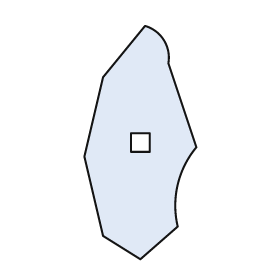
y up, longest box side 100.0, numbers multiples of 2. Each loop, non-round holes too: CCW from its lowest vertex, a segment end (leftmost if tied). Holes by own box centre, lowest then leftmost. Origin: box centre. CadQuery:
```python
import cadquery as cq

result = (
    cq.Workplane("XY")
    .moveTo(0.0, -50.0)
    .lineTo(16.0, -36.0)
    .threePointArc((16.0, -18.0), (24.0, -2.0))
    .lineTo(12.0, 34.0)
    .threePointArc((10.0, 44.0), (2.0, 50.0))
    .lineTo(-16.0, 28.0)
    .lineTo(-24.0, -6.0)
    .lineTo(-16.0, -40.0)
    .close()
    .moveTo(-4.0, -4.0)
    .lineTo(4.0, -4.0)
    .lineTo(4.0, 4.0)
    .lineTo(-4.0, 4.0)
    .close()
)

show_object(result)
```